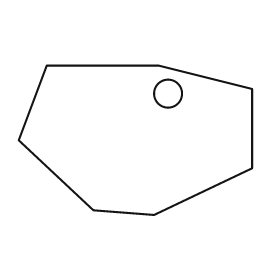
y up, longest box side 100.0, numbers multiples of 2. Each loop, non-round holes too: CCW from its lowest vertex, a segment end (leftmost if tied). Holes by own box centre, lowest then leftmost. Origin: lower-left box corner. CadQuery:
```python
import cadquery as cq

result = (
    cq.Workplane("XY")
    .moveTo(58.0, 0.0)
    .lineTo(100.0, 20.0)
    .lineTo(100.0, 54.0)
    .lineTo(60.0, 64.0)
    .lineTo(12.0, 64.0)
    .lineTo(0.0, 32.0)
    .lineTo(32.0, 2.0)
    .close()
    .moveTo(64.0, 52.0)
    .circle(6.0)
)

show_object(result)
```